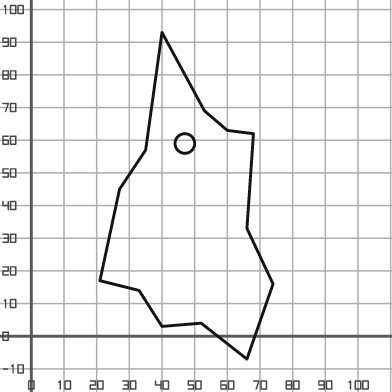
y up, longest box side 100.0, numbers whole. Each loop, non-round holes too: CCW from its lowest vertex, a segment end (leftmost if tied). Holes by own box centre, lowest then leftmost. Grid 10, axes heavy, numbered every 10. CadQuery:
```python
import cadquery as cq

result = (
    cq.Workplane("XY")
    .moveTo(66.0, -7.0)
    .lineTo(74.0, 16.0)
    .lineTo(66.0, 33.0)
    .lineTo(68.0, 62.0)
    .lineTo(60.0, 63.0)
    .lineTo(53.0, 69.0)
    .lineTo(40.0, 93.0)
    .lineTo(35.0, 57.0)
    .lineTo(27.0, 45.0)
    .lineTo(21.0, 17.0)
    .lineTo(33.0, 14.0)
    .lineTo(40.0, 3.0)
    .lineTo(52.0, 4.0)
    .close()
    .moveTo(47.0, 59.0)
    .circle(3.0)
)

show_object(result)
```